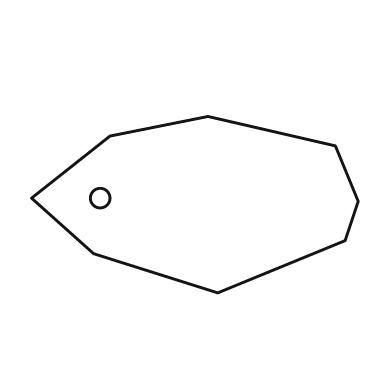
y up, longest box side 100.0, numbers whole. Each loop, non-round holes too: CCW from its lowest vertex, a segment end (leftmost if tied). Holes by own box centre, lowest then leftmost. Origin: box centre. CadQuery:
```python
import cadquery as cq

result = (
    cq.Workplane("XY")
    .moveTo(7.0, -27.0)
    .lineTo(46.0, -11.0)
    .lineTo(50.0, 1.0)
    .lineTo(43.0, 18.0)
    .lineTo(4.0, 27.0)
    .lineTo(-26.0, 21.0)
    .lineTo(-50.0, 2.0)
    .lineTo(-31.0, -15.0)
    .close()
    .moveTo(-29.0, 2.0)
    .circle(3.0)
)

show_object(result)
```